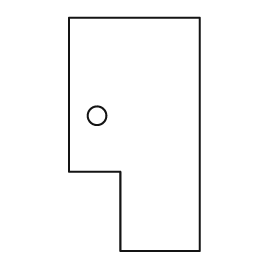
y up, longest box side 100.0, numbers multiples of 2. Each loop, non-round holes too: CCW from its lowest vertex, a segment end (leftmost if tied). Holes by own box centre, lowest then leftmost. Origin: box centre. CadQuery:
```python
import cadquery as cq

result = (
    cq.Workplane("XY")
    .moveTo(-6.0, -50.0)
    .lineTo(28.0, -50.0)
    .lineTo(28.0, 50.0)
    .lineTo(-28.0, 50.0)
    .lineTo(-28.0, -16.0)
    .lineTo(-6.0, -16.0)
    .close()
    .moveTo(-16.0, 8.0)
    .circle(4.0)
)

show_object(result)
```